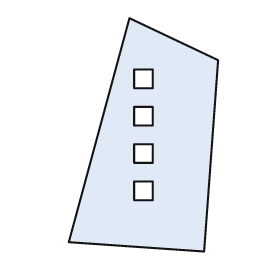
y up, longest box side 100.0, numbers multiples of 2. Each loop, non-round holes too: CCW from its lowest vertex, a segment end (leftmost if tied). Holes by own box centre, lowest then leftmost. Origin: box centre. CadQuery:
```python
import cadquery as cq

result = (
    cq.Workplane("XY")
    .moveTo(26.0, -50.0)
    .lineTo(32.0, 32.0)
    .lineTo(-6.0, 50.0)
    .lineTo(-32.0, -46.0)
    .close()
    .moveTo(-4.0, -28.0)
    .lineTo(4.0, -28.0)
    .lineTo(4.0, -20.0)
    .lineTo(-4.0, -20.0)
    .close()
    .moveTo(-4.0, -12.0)
    .lineTo(4.0, -12.0)
    .lineTo(4.0, -4.0)
    .lineTo(-4.0, -4.0)
    .close()
    .moveTo(-4.0, 4.0)
    .lineTo(4.0, 4.0)
    .lineTo(4.0, 12.0)
    .lineTo(-4.0, 12.0)
    .close()
    .moveTo(-4.0, 20.0)
    .lineTo(4.0, 20.0)
    .lineTo(4.0, 28.0)
    .lineTo(-4.0, 28.0)
    .close()
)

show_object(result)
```